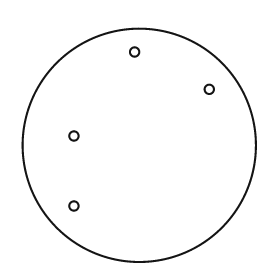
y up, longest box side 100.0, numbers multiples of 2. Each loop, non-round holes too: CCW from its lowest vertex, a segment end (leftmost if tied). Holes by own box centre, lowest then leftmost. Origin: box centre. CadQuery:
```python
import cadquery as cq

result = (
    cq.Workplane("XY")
    .moveTo(0.0, 0.0)
    .circle(50.0)
    .moveTo(-28.0, -26.0)
    .circle(2.0)
    .moveTo(-28.0, 4.0)
    .circle(2.0)
    .moveTo(30.0, 24.0)
    .circle(2.0)
    .moveTo(-2.0, 40.0)
    .circle(2.0)
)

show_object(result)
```